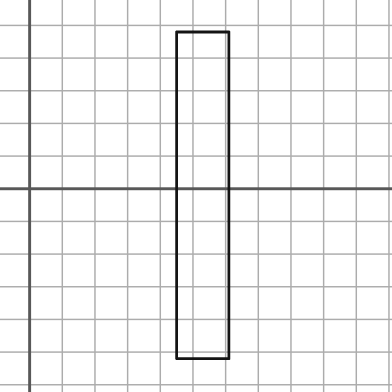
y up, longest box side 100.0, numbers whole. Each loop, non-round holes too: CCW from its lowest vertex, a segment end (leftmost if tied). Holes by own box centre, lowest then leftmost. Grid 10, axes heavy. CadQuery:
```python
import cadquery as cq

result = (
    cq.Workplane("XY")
    .moveTo(45.0, -52.0)
    .lineTo(61.0, -52.0)
    .lineTo(61.0, 48.0)
    .lineTo(45.0, 48.0)
    .close()
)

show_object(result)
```